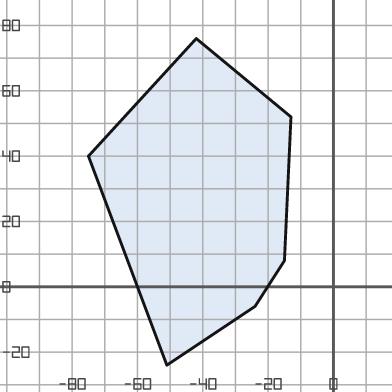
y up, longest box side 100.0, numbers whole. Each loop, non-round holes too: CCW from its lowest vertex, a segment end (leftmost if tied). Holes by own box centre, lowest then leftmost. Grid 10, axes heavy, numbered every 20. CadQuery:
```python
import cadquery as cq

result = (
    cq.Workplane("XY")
    .moveTo(-51.0, -24.0)
    .lineTo(-24.0, -6.0)
    .lineTo(-15.0, 8.0)
    .lineTo(-13.0, 52.0)
    .lineTo(-42.0, 76.0)
    .lineTo(-75.0, 40.0)
    .close()
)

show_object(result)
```